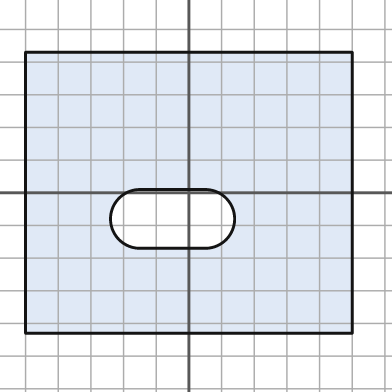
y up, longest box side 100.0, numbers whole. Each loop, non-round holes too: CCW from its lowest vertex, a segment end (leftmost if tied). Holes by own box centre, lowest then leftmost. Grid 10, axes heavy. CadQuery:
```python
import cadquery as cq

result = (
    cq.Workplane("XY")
    .moveTo(-50.0, -43.0)
    .lineTo(50.0, -43.0)
    .lineTo(50.0, 43.0)
    .lineTo(-50.0, 43.0)
    .close()
    .moveTo(-15.0, -17.0)
    .lineTo(5.0, -17.0)
    .threePointArc((14.0, -8.0), (5.0, 1.0))
    .lineTo(-15.0, 1.0)
    .threePointArc((-24.0, -8.0), (-15.0, -17.0))
    .close()
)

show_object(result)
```